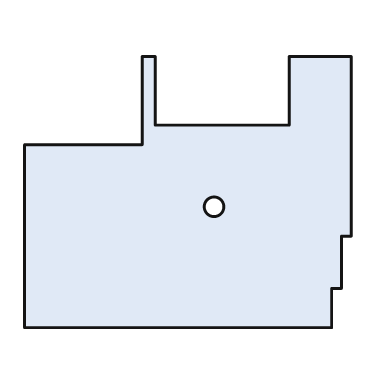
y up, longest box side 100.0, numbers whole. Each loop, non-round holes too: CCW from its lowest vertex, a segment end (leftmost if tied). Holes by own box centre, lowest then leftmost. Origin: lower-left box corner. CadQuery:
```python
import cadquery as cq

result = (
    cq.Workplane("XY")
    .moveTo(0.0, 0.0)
    .lineTo(94.0, 0.0)
    .lineTo(94.0, 12.0)
    .lineTo(97.0, 12.0)
    .lineTo(97.0, 28.0)
    .lineTo(100.0, 28.0)
    .lineTo(100.0, 83.0)
    .lineTo(81.0, 83.0)
    .lineTo(81.0, 62.0)
    .lineTo(40.0, 62.0)
    .lineTo(40.0, 83.0)
    .lineTo(36.0, 83.0)
    .lineTo(36.0, 56.0)
    .lineTo(0.0, 56.0)
    .close()
    .moveTo(58.0, 37.0)
    .circle(3.0)
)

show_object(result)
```